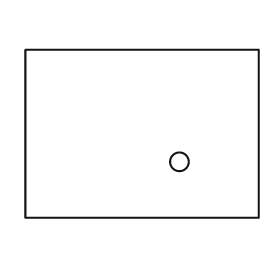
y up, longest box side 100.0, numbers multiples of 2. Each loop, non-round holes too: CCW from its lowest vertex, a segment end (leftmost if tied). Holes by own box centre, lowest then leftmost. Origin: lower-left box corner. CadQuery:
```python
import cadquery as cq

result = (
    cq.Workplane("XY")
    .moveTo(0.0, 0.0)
    .lineTo(100.0, 0.0)
    .lineTo(100.0, 72.0)
    .lineTo(0.0, 72.0)
    .close()
    .moveTo(66.0, 24.0)
    .circle(4.0)
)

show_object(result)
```